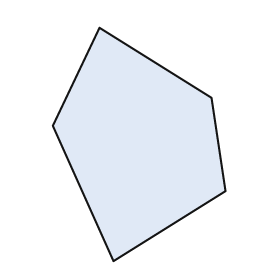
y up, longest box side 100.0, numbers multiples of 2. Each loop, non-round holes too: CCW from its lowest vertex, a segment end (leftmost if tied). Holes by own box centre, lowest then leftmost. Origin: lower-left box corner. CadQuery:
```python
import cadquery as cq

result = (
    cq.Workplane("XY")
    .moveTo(26.0, 0.0)
    .lineTo(74.0, 30.0)
    .lineTo(68.0, 70.0)
    .lineTo(20.0, 100.0)
    .lineTo(0.0, 58.0)
    .close()
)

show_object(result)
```